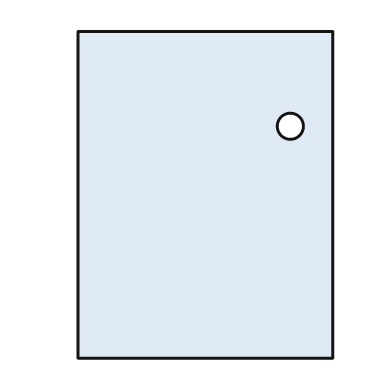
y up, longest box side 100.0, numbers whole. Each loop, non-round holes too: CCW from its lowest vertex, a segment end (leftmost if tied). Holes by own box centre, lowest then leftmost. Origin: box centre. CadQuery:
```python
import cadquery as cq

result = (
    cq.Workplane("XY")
    .moveTo(-39.0, -50.0)
    .lineTo(39.0, -50.0)
    .lineTo(39.0, 50.0)
    .lineTo(-39.0, 50.0)
    .close()
    .moveTo(26.0, 21.0)
    .circle(4.0)
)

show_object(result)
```